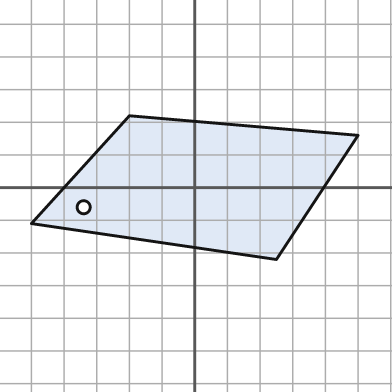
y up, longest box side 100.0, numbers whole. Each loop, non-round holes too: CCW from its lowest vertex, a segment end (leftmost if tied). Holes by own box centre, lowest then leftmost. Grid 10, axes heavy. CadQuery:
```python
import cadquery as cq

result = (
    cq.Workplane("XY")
    .moveTo(25.0, -22.0)
    .lineTo(50.0, 16.0)
    .lineTo(-20.0, 22.0)
    .lineTo(-50.0, -11.0)
    .close()
    .moveTo(-34.0, -6.0)
    .circle(2.0)
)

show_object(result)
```